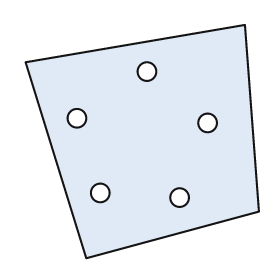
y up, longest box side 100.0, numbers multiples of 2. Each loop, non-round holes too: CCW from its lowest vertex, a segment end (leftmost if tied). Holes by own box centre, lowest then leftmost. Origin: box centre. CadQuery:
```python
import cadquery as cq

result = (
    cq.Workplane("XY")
    .moveTo(-24.0, -50.0)
    .lineTo(50.0, -30.0)
    .lineTo(44.0, 50.0)
    .lineTo(-50.0, 34.0)
    .close()
    .moveTo(16.0, -24.0)
    .circle(4.0)
    .moveTo(-18.0, -22.0)
    .circle(4.0)
    .moveTo(28.0, 8.0)
    .circle(4.0)
    .moveTo(-28.0, 10.0)
    .circle(4.0)
    .moveTo(2.0, 30.0)
    .circle(4.0)
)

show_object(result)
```